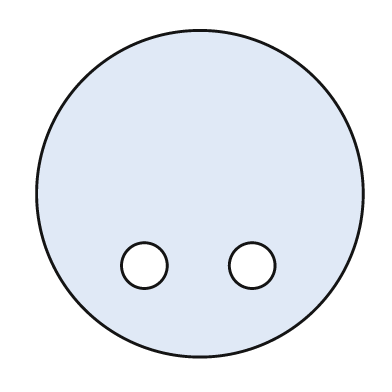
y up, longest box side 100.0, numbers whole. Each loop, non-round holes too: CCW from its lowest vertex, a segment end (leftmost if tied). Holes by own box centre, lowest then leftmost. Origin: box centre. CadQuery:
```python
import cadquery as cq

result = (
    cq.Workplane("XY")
    .moveTo(0.0, 0.0)
    .circle(50.0)
    .moveTo(-17.0, -22.0)
    .circle(7.0)
    .moveTo(16.0, -22.0)
    .circle(7.0)
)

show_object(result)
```